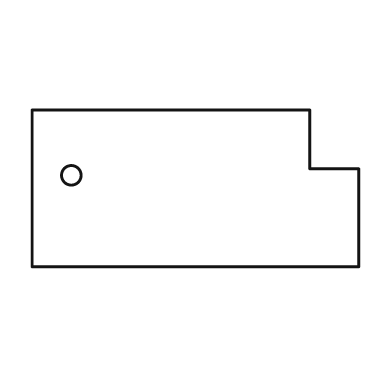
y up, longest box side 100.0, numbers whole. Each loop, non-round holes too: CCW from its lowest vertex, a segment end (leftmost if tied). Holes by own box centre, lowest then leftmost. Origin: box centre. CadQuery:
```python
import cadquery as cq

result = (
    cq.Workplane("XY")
    .moveTo(-50.0, -24.0)
    .lineTo(50.0, -24.0)
    .lineTo(50.0, 6.0)
    .lineTo(35.0, 6.0)
    .lineTo(35.0, 24.0)
    .lineTo(-50.0, 24.0)
    .close()
    .moveTo(-38.0, 4.0)
    .circle(3.0)
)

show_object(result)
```